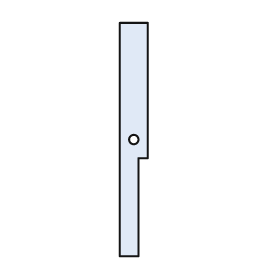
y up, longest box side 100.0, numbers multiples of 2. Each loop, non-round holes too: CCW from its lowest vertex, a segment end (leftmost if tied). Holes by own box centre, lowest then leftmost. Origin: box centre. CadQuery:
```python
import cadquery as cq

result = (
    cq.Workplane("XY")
    .moveTo(-6.0, -50.0)
    .lineTo(2.0, -50.0)
    .lineTo(2.0, -8.0)
    .lineTo(6.0, -8.0)
    .lineTo(6.0, 50.0)
    .lineTo(-6.0, 50.0)
    .close()
    .moveTo(0.0, 0.0)
    .circle(2.0)
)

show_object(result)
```